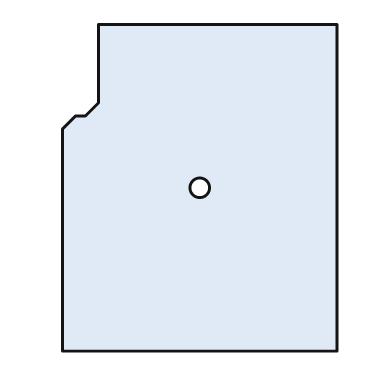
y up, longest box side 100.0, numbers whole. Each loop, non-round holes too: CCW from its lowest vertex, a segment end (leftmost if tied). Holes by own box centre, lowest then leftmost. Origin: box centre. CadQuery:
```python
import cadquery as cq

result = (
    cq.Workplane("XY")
    .moveTo(-42.0, -50.0)
    .lineTo(42.0, -50.0)
    .lineTo(42.0, 50.0)
    .lineTo(-31.0, 50.0)
    .lineTo(-31.0, 26.0)
    .lineTo(-35.0, 22.0)
    .lineTo(-38.0, 22.0)
    .lineTo(-42.0, 18.0)
    .close()
    .moveTo(0.0, 0.0)
    .circle(3.0)
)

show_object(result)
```